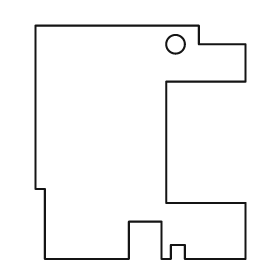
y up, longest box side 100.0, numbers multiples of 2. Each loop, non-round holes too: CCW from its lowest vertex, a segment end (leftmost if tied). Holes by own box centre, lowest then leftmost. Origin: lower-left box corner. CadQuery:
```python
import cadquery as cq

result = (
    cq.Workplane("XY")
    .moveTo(4.0, 0.0)
    .lineTo(40.0, 0.0)
    .lineTo(40.0, 16.0)
    .lineTo(54.0, 16.0)
    .lineTo(54.0, 0.0)
    .lineTo(58.0, 0.0)
    .lineTo(58.0, 6.0)
    .lineTo(64.0, 6.0)
    .lineTo(64.0, 0.0)
    .lineTo(90.0, 0.0)
    .lineTo(90.0, 24.0)
    .lineTo(56.0, 24.0)
    .lineTo(56.0, 76.0)
    .lineTo(90.0, 76.0)
    .lineTo(90.0, 92.0)
    .lineTo(70.0, 92.0)
    .lineTo(70.0, 100.0)
    .lineTo(0.0, 100.0)
    .lineTo(0.0, 30.0)
    .lineTo(4.0, 30.0)
    .close()
    .moveTo(60.0, 92.0)
    .circle(4.0)
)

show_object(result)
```